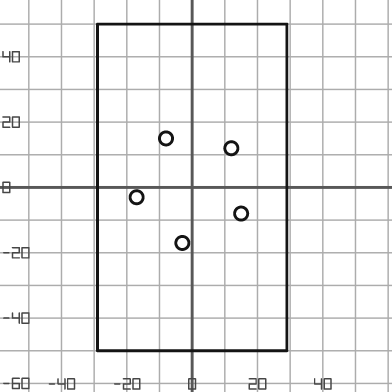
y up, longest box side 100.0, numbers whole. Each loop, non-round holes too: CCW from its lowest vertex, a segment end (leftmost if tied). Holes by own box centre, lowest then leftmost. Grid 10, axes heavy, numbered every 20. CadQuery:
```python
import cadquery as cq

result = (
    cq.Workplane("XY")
    .moveTo(-29.0, -50.0)
    .lineTo(29.0, -50.0)
    .lineTo(29.0, 50.0)
    .lineTo(-29.0, 50.0)
    .close()
    .moveTo(-3.0, -17.0)
    .circle(2.0)
    .moveTo(15.0, -8.0)
    .circle(2.0)
    .moveTo(-17.0, -3.0)
    .circle(2.0)
    .moveTo(12.0, 12.0)
    .circle(2.0)
    .moveTo(-8.0, 15.0)
    .circle(2.0)
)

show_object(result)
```